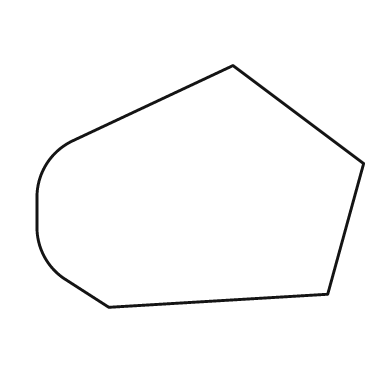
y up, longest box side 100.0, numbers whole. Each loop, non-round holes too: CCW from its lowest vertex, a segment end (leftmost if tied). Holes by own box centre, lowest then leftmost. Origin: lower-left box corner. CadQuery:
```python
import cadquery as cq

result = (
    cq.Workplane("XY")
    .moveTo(22.0, 0.0)
    .lineTo(89.0, 4.0)
    .lineTo(100.0, 44.0)
    .lineTo(60.0, 74.0)
    .lineTo(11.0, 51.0)
    .threePointArc((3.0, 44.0), (0.0, 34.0))
    .lineTo(0.0, 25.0)
    .threePointArc((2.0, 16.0), (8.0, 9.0))
    .close()
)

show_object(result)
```